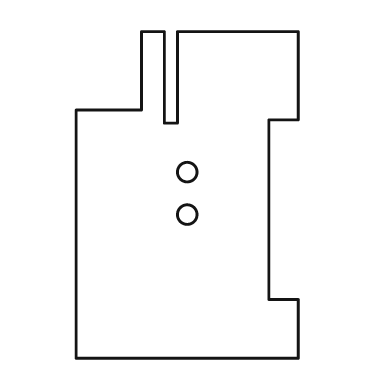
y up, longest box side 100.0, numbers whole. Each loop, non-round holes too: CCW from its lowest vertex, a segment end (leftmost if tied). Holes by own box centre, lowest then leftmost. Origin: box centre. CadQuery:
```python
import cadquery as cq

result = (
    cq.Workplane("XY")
    .moveTo(-34.0, -50.0)
    .lineTo(34.0, -50.0)
    .lineTo(34.0, -32.0)
    .lineTo(25.0, -32.0)
    .lineTo(25.0, 23.0)
    .lineTo(34.0, 23.0)
    .lineTo(34.0, 50.0)
    .lineTo(-3.0, 50.0)
    .lineTo(-3.0, 22.0)
    .lineTo(-7.0, 22.0)
    .lineTo(-7.0, 50.0)
    .lineTo(-14.0, 50.0)
    .lineTo(-14.0, 26.0)
    .lineTo(-34.0, 26.0)
    .close()
    .moveTo(0.0, -6.0)
    .circle(3.0)
    .moveTo(0.0, 7.0)
    .circle(3.0)
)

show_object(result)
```